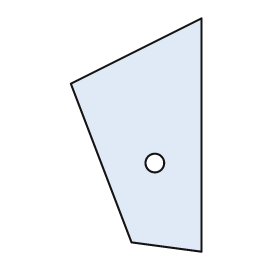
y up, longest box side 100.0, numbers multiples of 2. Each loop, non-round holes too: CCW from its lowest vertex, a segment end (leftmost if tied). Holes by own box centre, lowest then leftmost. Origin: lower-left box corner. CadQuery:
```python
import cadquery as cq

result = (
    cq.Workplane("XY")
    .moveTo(56.0, 0.0)
    .lineTo(56.0, 100.0)
    .lineTo(0.0, 72.0)
    .lineTo(26.0, 4.0)
    .close()
    .moveTo(36.0, 38.0)
    .circle(4.0)
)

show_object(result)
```